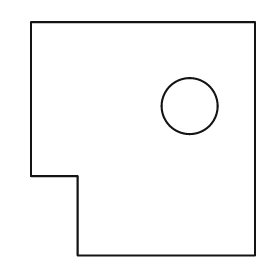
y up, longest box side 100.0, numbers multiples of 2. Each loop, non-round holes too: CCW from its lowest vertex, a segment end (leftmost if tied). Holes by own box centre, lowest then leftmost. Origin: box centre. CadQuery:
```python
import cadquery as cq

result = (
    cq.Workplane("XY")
    .moveTo(-28.0, -50.0)
    .lineTo(48.0, -50.0)
    .lineTo(48.0, 50.0)
    .lineTo(-48.0, 50.0)
    .lineTo(-48.0, -16.0)
    .lineTo(-28.0, -16.0)
    .close()
    .moveTo(20.0, 14.0)
    .circle(12.0)
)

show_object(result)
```